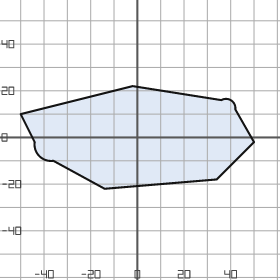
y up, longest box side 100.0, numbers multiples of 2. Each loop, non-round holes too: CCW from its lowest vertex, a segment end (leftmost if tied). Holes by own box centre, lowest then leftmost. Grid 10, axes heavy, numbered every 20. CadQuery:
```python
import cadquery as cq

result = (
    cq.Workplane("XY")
    .moveTo(-14.0, -22.0)
    .lineTo(34.0, -18.0)
    .lineTo(50.0, -2.0)
    .lineTo(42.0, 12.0)
    .threePointArc((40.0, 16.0), (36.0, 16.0))
    .lineTo(-2.0, 22.0)
    .lineTo(-50.0, 10.0)
    .lineTo(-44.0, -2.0)
    .threePointArc((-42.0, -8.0), (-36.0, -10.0))
    .close()
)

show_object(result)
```